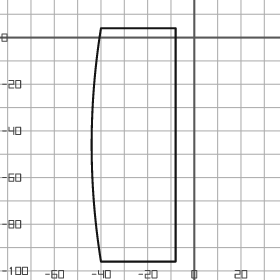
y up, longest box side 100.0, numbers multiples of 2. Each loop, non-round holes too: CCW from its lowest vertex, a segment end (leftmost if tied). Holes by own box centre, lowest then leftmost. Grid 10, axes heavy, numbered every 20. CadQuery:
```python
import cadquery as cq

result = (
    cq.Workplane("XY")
    .moveTo(-40.0, -96.0)
    .lineTo(-8.0, -96.0)
    .lineTo(-8.0, 4.0)
    .lineTo(-40.0, 4.0)
    .threePointArc((-44.0, -46.0), (-40.0, -96.0))
    .close()
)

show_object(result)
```